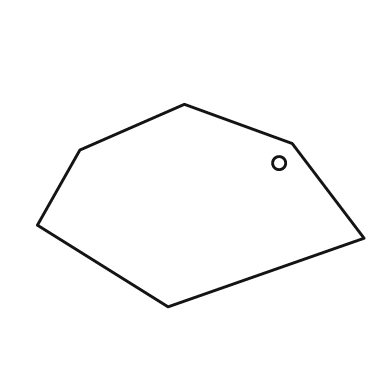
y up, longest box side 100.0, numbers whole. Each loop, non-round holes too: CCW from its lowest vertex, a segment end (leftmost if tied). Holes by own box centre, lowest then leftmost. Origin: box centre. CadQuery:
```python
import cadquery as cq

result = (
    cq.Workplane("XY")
    .moveTo(-10.0, -31.0)
    .lineTo(50.0, -10.0)
    .lineTo(28.0, 19.0)
    .lineTo(-5.0, 31.0)
    .lineTo(-37.0, 17.0)
    .lineTo(-50.0, -6.0)
    .close()
    .moveTo(24.0, 13.0)
    .circle(2.0)
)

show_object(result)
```